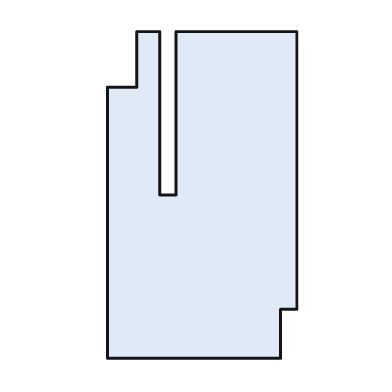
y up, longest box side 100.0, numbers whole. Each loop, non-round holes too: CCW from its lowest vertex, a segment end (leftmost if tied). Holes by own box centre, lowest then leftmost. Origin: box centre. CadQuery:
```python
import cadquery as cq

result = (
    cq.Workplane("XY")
    .moveTo(-29.0, -50.0)
    .lineTo(24.0, -50.0)
    .lineTo(24.0, -35.0)
    .lineTo(29.0, -35.0)
    .lineTo(29.0, 50.0)
    .lineTo(-8.0, 50.0)
    .lineTo(-8.0, 0.0)
    .lineTo(-13.0, 0.0)
    .lineTo(-13.0, 50.0)
    .lineTo(-20.0, 50.0)
    .lineTo(-20.0, 33.0)
    .lineTo(-29.0, 33.0)
    .close()
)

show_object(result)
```